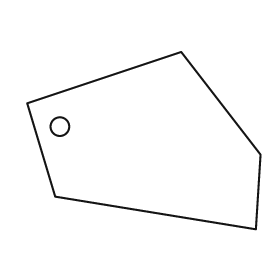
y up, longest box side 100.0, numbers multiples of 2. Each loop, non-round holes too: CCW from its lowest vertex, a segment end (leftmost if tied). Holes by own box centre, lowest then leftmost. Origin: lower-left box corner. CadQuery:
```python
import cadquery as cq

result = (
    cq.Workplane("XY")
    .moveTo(98.0, 0.0)
    .lineTo(100.0, 32.0)
    .lineTo(66.0, 76.0)
    .lineTo(0.0, 54.0)
    .lineTo(12.0, 14.0)
    .close()
    .moveTo(14.0, 44.0)
    .circle(4.0)
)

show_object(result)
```